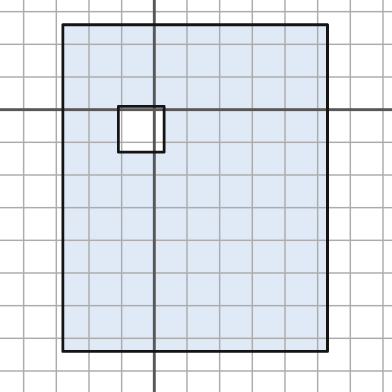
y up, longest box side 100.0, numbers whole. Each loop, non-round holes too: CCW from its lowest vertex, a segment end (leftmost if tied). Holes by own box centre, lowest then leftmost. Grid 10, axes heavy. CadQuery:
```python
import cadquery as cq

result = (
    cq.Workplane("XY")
    .moveTo(-28.0, -74.0)
    .lineTo(53.0, -74.0)
    .lineTo(53.0, 26.0)
    .lineTo(-28.0, 26.0)
    .close()
    .moveTo(-11.0, -13.0)
    .lineTo(3.0, -13.0)
    .lineTo(3.0, 1.0)
    .lineTo(-11.0, 1.0)
    .close()
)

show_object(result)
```